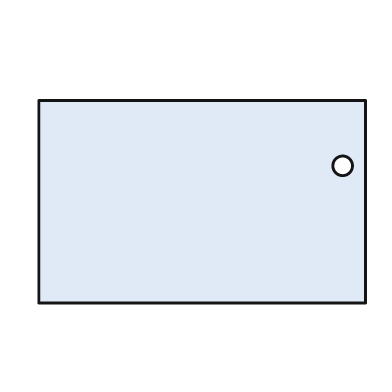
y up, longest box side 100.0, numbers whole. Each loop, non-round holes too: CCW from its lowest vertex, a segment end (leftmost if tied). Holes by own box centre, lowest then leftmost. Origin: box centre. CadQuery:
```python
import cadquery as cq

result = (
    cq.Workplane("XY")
    .moveTo(-50.0, -31.0)
    .lineTo(50.0, -31.0)
    .lineTo(50.0, 31.0)
    .lineTo(-50.0, 31.0)
    .close()
    .moveTo(43.0, 11.0)
    .circle(3.0)
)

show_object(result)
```